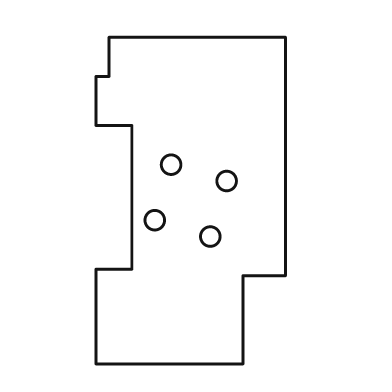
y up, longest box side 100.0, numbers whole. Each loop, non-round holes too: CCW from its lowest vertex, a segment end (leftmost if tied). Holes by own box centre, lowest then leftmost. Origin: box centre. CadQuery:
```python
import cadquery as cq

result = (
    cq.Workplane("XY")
    .moveTo(-29.0, -50.0)
    .lineTo(16.0, -50.0)
    .lineTo(16.0, -23.0)
    .lineTo(29.0, -23.0)
    .lineTo(29.0, 50.0)
    .lineTo(-25.0, 50.0)
    .lineTo(-25.0, 38.0)
    .lineTo(-29.0, 38.0)
    .lineTo(-29.0, 23.0)
    .lineTo(-18.0, 23.0)
    .lineTo(-18.0, -21.0)
    .lineTo(-29.0, -21.0)
    .close()
    .moveTo(6.0, -11.0)
    .circle(3.0)
    .moveTo(-11.0, -6.0)
    .circle(3.0)
    .moveTo(11.0, 6.0)
    .circle(3.0)
    .moveTo(-6.0, 11.0)
    .circle(3.0)
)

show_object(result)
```